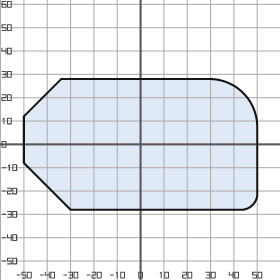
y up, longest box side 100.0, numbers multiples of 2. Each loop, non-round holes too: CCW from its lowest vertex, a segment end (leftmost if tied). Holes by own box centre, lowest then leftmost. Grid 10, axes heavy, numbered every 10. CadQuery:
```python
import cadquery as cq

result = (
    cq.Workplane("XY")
    .moveTo(-30.0, -28.0)
    .lineTo(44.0, -28.0)
    .threePointArc((48.0, -26.0), (50.0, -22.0))
    .lineTo(50.0, 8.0)
    .threePointArc((44.0, 22.0), (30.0, 28.0))
    .lineTo(-34.0, 28.0)
    .lineTo(-50.0, 12.0)
    .lineTo(-50.0, -8.0)
    .close()
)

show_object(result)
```